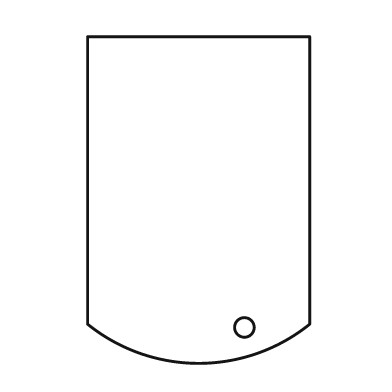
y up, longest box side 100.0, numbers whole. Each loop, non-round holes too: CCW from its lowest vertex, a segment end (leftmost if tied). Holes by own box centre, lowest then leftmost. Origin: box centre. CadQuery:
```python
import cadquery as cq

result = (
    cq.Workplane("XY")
    .moveTo(-34.0, -38.0)
    .threePointArc((0.0, -50.0), (34.0, -38.0))
    .lineTo(34.0, 50.0)
    .lineTo(-34.0, 50.0)
    .close()
    .moveTo(14.0, -39.0)
    .circle(3.0)
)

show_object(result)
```